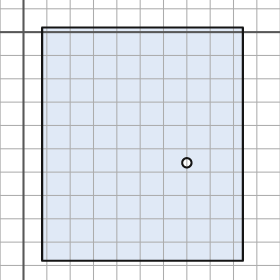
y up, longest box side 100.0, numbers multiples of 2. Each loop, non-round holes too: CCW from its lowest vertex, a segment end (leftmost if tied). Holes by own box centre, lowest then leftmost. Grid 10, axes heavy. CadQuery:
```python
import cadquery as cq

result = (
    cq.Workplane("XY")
    .moveTo(8.0, -98.0)
    .lineTo(94.0, -98.0)
    .lineTo(94.0, 2.0)
    .lineTo(8.0, 2.0)
    .close()
    .moveTo(70.0, -56.0)
    .circle(2.0)
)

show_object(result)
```